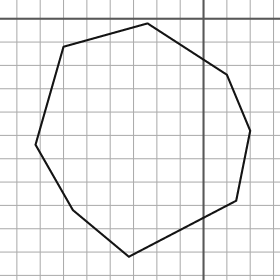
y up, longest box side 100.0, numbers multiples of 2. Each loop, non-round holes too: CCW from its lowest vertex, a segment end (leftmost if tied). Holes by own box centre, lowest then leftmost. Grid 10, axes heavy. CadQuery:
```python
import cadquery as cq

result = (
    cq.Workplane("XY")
    .moveTo(-32.0, -102.0)
    .lineTo(14.0, -78.0)
    .lineTo(20.0, -48.0)
    .lineTo(10.0, -24.0)
    .lineTo(-24.0, -2.0)
    .lineTo(-60.0, -12.0)
    .lineTo(-72.0, -54.0)
    .lineTo(-56.0, -82.0)
    .close()
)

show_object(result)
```